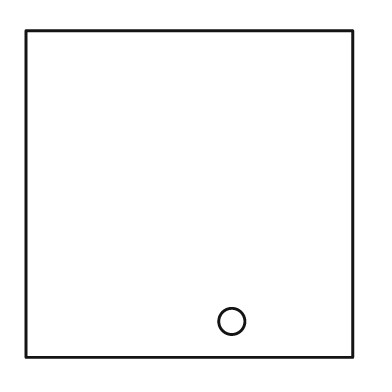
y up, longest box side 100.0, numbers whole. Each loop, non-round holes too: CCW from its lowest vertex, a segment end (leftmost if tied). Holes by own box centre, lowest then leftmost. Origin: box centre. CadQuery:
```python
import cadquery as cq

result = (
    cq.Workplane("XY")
    .moveTo(-50.0, -50.0)
    .lineTo(50.0, -50.0)
    .lineTo(50.0, 50.0)
    .lineTo(-50.0, 50.0)
    .close()
    .moveTo(13.0, -39.0)
    .circle(4.0)
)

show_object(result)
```